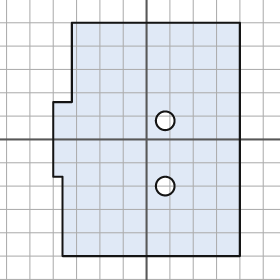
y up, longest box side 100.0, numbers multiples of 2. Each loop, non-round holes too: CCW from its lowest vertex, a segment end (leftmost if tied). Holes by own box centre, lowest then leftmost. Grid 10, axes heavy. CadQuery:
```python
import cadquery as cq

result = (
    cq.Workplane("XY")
    .moveTo(-36.0, -50.0)
    .lineTo(40.0, -50.0)
    .lineTo(40.0, 50.0)
    .lineTo(-32.0, 50.0)
    .lineTo(-32.0, 16.0)
    .lineTo(-40.0, 16.0)
    .lineTo(-40.0, -16.0)
    .lineTo(-36.0, -16.0)
    .close()
    .moveTo(8.0, -20.0)
    .circle(4.0)
    .moveTo(8.0, 8.0)
    .circle(4.0)
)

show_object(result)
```